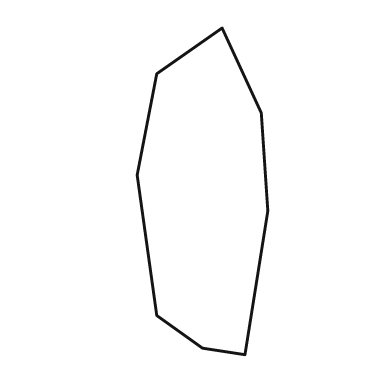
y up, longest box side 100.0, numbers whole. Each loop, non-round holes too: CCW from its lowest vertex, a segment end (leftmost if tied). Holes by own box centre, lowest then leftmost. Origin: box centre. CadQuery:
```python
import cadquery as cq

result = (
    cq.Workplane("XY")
    .moveTo(13.0, -50.0)
    .lineTo(20.0, -6.0)
    .lineTo(18.0, 24.0)
    .lineTo(6.0, 50.0)
    .lineTo(-14.0, 36.0)
    .lineTo(-20.0, 5.0)
    .lineTo(-14.0, -38.0)
    .lineTo(0.0, -48.0)
    .close()
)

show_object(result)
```